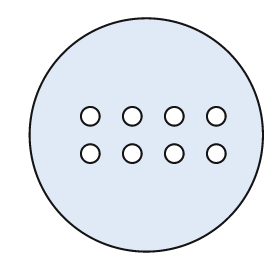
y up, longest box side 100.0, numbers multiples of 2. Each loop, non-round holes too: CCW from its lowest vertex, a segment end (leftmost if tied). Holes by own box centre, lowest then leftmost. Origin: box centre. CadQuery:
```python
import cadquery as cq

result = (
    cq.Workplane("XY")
    .moveTo(0.0, 0.0)
    .circle(50.0)
    .moveTo(-24.0, -8.0)
    .circle(4.0)
    .moveTo(-6.0, -8.0)
    .circle(4.0)
    .moveTo(12.0, -8.0)
    .circle(4.0)
    .moveTo(30.0, -8.0)
    .circle(4.0)
    .moveTo(-24.0, 8.0)
    .circle(4.0)
    .moveTo(-6.0, 8.0)
    .circle(4.0)
    .moveTo(12.0, 8.0)
    .circle(4.0)
    .moveTo(30.0, 8.0)
    .circle(4.0)
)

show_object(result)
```